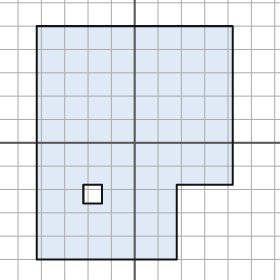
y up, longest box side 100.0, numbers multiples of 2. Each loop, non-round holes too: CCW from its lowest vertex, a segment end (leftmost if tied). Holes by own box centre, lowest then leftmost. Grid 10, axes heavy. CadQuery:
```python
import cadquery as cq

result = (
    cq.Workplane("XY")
    .moveTo(-42.0, -50.0)
    .lineTo(18.0, -50.0)
    .lineTo(18.0, -18.0)
    .lineTo(42.0, -18.0)
    .lineTo(42.0, 50.0)
    .lineTo(-42.0, 50.0)
    .close()
    .moveTo(-22.0, -26.0)
    .lineTo(-14.0, -26.0)
    .lineTo(-14.0, -18.0)
    .lineTo(-22.0, -18.0)
    .close()
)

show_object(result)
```